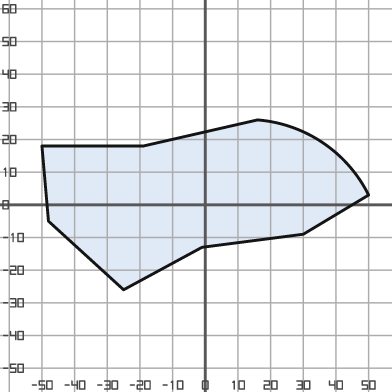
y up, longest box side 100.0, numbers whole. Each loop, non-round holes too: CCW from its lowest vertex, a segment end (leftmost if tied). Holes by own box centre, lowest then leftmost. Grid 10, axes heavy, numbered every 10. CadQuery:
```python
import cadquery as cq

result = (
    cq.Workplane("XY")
    .moveTo(-25.0, -26.0)
    .lineTo(-1.0, -13.0)
    .lineTo(30.0, -9.0)
    .lineTo(50.0, 3.0)
    .threePointArc((36.0, 19.0), (16.0, 26.0))
    .lineTo(-19.0, 18.0)
    .lineTo(-50.0, 18.0)
    .lineTo(-48.0, -5.0)
    .close()
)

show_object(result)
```